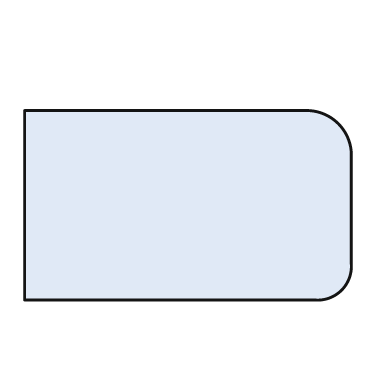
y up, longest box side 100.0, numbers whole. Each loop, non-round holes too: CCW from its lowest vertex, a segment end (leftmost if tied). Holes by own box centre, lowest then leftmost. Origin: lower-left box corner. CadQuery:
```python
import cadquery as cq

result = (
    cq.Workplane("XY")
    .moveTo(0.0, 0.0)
    .lineTo(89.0, 0.0)
    .threePointArc((97.0, 3.0), (100.0, 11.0))
    .lineTo(100.0, 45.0)
    .threePointArc((96.0, 54.0), (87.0, 58.0))
    .lineTo(0.0, 58.0)
    .close()
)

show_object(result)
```